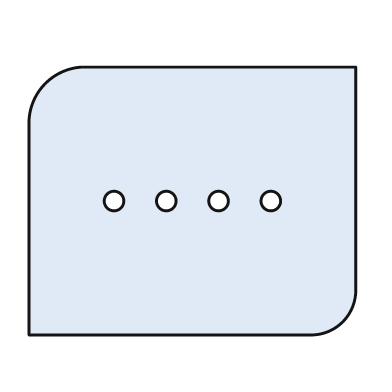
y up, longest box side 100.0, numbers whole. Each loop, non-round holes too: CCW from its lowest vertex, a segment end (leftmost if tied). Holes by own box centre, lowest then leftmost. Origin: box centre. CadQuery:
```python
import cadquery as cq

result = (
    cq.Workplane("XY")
    .moveTo(-50.0, -41.0)
    .lineTo(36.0, -41.0)
    .threePointArc((46.0, -37.0), (50.0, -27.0))
    .lineTo(50.0, 41.0)
    .lineTo(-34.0, 41.0)
    .threePointArc((-45.0, 36.0), (-50.0, 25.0))
    .close()
    .moveTo(-24.0, 0.0)
    .circle(3.0)
    .moveTo(-8.0, 0.0)
    .circle(3.0)
    .moveTo(8.0, 0.0)
    .circle(3.0)
    .moveTo(24.0, 0.0)
    .circle(3.0)
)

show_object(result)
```